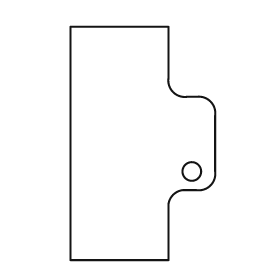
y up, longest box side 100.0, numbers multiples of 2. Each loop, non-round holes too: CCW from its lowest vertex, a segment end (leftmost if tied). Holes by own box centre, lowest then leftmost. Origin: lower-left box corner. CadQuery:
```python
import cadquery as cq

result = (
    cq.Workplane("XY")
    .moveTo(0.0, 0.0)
    .lineTo(42.0, 0.0)
    .lineTo(42.0, 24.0)
    .threePointArc((44.0, 28.0), (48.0, 30.0))
    .lineTo(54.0, 30.0)
    .threePointArc((60.0, 32.0), (62.0, 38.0))
    .lineTo(62.0, 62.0)
    .threePointArc((60.0, 68.0), (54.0, 70.0))
    .lineTo(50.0, 70.0)
    .threePointArc((44.0, 72.0), (42.0, 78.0))
    .lineTo(42.0, 100.0)
    .lineTo(0.0, 100.0)
    .close()
    .moveTo(52.0, 38.0)
    .circle(4.0)
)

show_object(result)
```